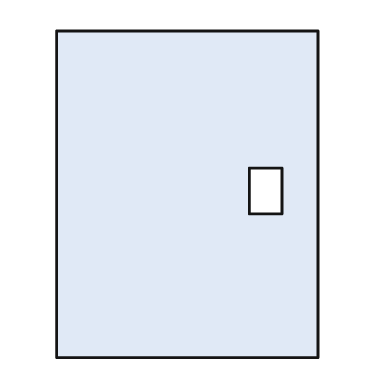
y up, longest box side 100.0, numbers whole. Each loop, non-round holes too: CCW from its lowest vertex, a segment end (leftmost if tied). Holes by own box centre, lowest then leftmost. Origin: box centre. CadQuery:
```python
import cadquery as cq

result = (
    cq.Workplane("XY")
    .moveTo(-40.0, -50.0)
    .lineTo(40.0, -50.0)
    .lineTo(40.0, 50.0)
    .lineTo(-40.0, 50.0)
    .close()
    .moveTo(19.0, -6.0)
    .lineTo(29.0, -6.0)
    .lineTo(29.0, 8.0)
    .lineTo(19.0, 8.0)
    .close()
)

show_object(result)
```